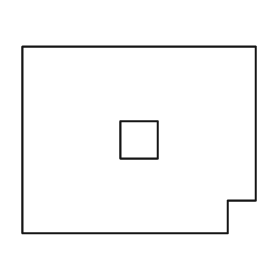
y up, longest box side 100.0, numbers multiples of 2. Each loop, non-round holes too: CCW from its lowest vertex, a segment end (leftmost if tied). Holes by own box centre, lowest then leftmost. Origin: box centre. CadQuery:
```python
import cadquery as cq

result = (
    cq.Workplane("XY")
    .moveTo(-50.0, -40.0)
    .lineTo(38.0, -40.0)
    .lineTo(38.0, -26.0)
    .lineTo(50.0, -26.0)
    .lineTo(50.0, 40.0)
    .lineTo(-50.0, 40.0)
    .close()
    .moveTo(-8.0, -8.0)
    .lineTo(8.0, -8.0)
    .lineTo(8.0, 8.0)
    .lineTo(-8.0, 8.0)
    .close()
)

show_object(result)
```